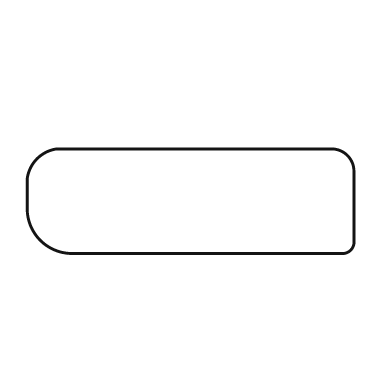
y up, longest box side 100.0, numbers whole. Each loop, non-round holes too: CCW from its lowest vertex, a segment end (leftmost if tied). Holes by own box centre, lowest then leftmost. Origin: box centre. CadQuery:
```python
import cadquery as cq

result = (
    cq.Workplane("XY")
    .moveTo(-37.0, -16.0)
    .lineTo(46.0, -16.0)
    .threePointArc((49.0, -15.0), (50.0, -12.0))
    .lineTo(50.0, 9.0)
    .threePointArc((48.0, 14.0), (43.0, 16.0))
    .lineTo(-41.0, 16.0)
    .threePointArc((-47.0, 13.0), (-50.0, 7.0))
    .lineTo(-50.0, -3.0)
    .threePointArc((-46.0, -12.0), (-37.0, -16.0))
    .close()
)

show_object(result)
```